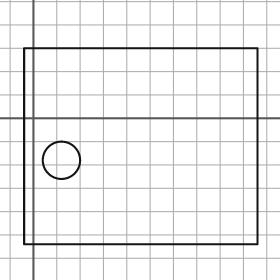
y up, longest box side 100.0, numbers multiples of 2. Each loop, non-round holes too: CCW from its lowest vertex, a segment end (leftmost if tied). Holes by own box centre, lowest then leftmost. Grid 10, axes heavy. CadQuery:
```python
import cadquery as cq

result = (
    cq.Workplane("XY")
    .moveTo(-4.0, -54.0)
    .lineTo(96.0, -54.0)
    .lineTo(96.0, 30.0)
    .lineTo(-4.0, 30.0)
    .close()
    .moveTo(12.0, -18.0)
    .circle(8.0)
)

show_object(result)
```